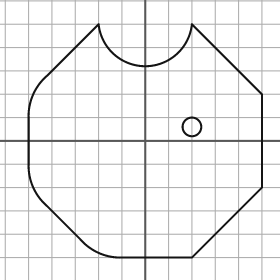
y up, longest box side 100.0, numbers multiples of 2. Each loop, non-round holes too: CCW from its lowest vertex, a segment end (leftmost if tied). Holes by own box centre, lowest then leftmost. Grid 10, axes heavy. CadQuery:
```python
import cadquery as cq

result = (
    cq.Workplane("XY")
    .moveTo(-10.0, -50.0)
    .lineTo(20.0, -50.0)
    .lineTo(50.0, -20.0)
    .lineTo(50.0, 20.0)
    .lineTo(20.0, 50.0)
    .threePointArc((0.0, 32.0), (-20.0, 50.0))
    .lineTo(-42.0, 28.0)
    .threePointArc((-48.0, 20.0), (-50.0, 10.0))
    .lineTo(-50.0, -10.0)
    .threePointArc((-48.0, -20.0), (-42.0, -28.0))
    .lineTo(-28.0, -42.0)
    .threePointArc((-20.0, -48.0), (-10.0, -50.0))
    .close()
    .moveTo(20.0, 6.0)
    .circle(4.0)
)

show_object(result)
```